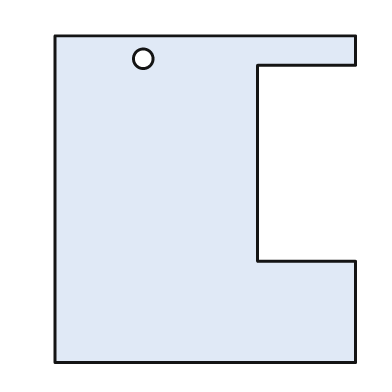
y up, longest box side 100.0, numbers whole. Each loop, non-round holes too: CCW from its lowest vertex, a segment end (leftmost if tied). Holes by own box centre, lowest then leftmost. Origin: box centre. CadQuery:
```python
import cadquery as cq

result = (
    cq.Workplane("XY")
    .moveTo(-46.0, -50.0)
    .lineTo(46.0, -50.0)
    .lineTo(46.0, -19.0)
    .lineTo(16.0, -19.0)
    .lineTo(16.0, 41.0)
    .lineTo(46.0, 41.0)
    .lineTo(46.0, 50.0)
    .lineTo(-46.0, 50.0)
    .close()
    .moveTo(-19.0, 43.0)
    .circle(3.0)
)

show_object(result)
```